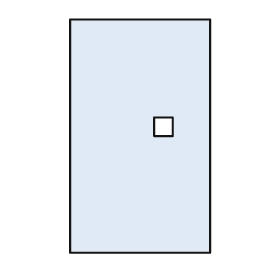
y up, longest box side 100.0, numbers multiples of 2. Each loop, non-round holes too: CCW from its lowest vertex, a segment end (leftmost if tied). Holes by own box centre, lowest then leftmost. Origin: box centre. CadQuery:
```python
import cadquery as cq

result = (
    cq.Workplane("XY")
    .moveTo(-30.0, -50.0)
    .lineTo(30.0, -50.0)
    .lineTo(30.0, 50.0)
    .lineTo(-30.0, 50.0)
    .close()
    .moveTo(6.0, 0.0)
    .lineTo(14.0, 0.0)
    .lineTo(14.0, 8.0)
    .lineTo(6.0, 8.0)
    .close()
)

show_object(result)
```